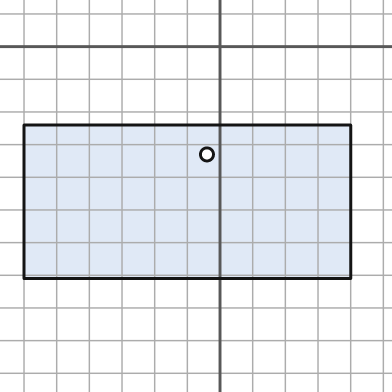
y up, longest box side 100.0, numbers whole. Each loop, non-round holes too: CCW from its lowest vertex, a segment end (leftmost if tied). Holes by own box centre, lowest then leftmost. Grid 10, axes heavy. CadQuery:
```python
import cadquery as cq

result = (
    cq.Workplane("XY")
    .moveTo(-60.0, -71.0)
    .lineTo(40.0, -71.0)
    .lineTo(40.0, -24.0)
    .lineTo(-60.0, -24.0)
    .close()
    .moveTo(-4.0, -33.0)
    .circle(2.0)
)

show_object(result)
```